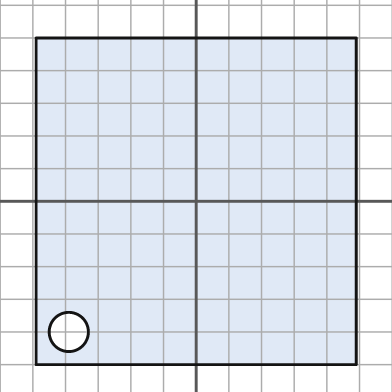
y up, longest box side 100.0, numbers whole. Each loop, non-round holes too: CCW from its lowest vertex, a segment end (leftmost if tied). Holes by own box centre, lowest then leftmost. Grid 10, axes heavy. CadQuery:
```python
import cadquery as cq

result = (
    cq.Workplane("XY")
    .moveTo(-49.0, -50.0)
    .lineTo(49.0, -50.0)
    .lineTo(49.0, 50.0)
    .lineTo(-49.0, 50.0)
    .close()
    .moveTo(-39.0, -40.0)
    .circle(6.0)
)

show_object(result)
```